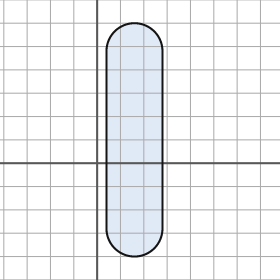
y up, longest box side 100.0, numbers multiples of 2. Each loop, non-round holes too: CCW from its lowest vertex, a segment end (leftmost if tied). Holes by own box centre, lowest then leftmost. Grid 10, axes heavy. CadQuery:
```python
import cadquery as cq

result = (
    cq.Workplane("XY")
    .moveTo(4.0, -28.0)
    .threePointArc((16.0, -40.0), (28.0, -28.0))
    .lineTo(28.0, 48.0)
    .threePointArc((16.0, 60.0), (4.0, 48.0))
    .close()
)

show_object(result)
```